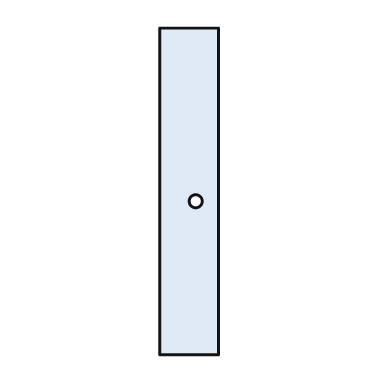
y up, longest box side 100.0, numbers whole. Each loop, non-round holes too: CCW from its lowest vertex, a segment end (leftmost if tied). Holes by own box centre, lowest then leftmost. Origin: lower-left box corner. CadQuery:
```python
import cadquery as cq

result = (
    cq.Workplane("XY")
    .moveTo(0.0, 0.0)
    .lineTo(18.0, 0.0)
    .lineTo(18.0, 100.0)
    .lineTo(0.0, 100.0)
    .close()
    .moveTo(11.0, 47.0)
    .circle(2.0)
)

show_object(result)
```